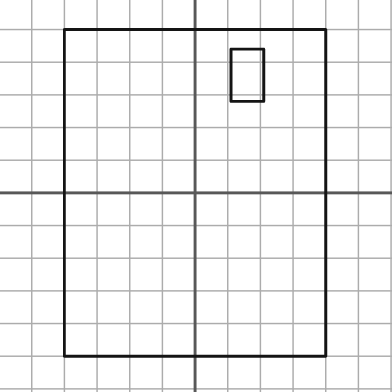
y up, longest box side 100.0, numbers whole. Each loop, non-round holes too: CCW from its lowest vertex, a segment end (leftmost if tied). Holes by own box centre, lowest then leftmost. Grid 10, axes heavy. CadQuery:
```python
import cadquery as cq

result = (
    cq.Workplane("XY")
    .moveTo(-40.0, -50.0)
    .lineTo(40.0, -50.0)
    .lineTo(40.0, 50.0)
    .lineTo(-40.0, 50.0)
    .close()
    .moveTo(11.0, 28.0)
    .lineTo(21.0, 28.0)
    .lineTo(21.0, 44.0)
    .lineTo(11.0, 44.0)
    .close()
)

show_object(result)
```